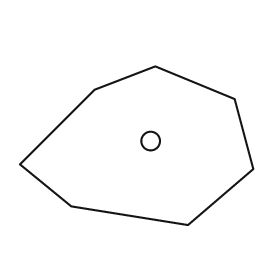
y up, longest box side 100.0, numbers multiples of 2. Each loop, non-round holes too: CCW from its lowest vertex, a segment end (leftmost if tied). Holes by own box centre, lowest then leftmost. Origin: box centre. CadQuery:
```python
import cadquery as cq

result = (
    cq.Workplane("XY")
    .moveTo(22.0, -34.0)
    .lineTo(50.0, -10.0)
    .lineTo(42.0, 20.0)
    .lineTo(8.0, 34.0)
    .lineTo(-18.0, 24.0)
    .lineTo(-50.0, -8.0)
    .lineTo(-28.0, -26.0)
    .close()
    .moveTo(6.0, 2.0)
    .circle(4.0)
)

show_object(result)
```